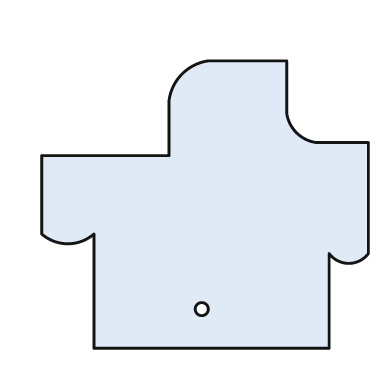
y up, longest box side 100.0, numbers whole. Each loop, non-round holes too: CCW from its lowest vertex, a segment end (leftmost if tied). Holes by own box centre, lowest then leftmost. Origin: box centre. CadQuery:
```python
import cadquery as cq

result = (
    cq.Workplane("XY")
    .moveTo(-34.0, -44.0)
    .lineTo(38.0, -44.0)
    .lineTo(38.0, -15.0)
    .threePointArc((44.0, -18.0), (50.0, -15.0))
    .lineTo(50.0, 19.0)
    .lineTo(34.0, 19.0)
    .threePointArc((28.0, 22.0), (25.0, 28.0))
    .lineTo(25.0, 44.0)
    .lineTo(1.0, 44.0)
    .threePointArc((-7.0, 40.0), (-11.0, 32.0))
    .lineTo(-11.0, 15.0)
    .lineTo(-50.0, 15.0)
    .lineTo(-50.0, -9.0)
    .threePointArc((-42.0, -12.0), (-34.0, -9.0))
    .close()
    .moveTo(-1.0, -32.0)
    .circle(2.0)
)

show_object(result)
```